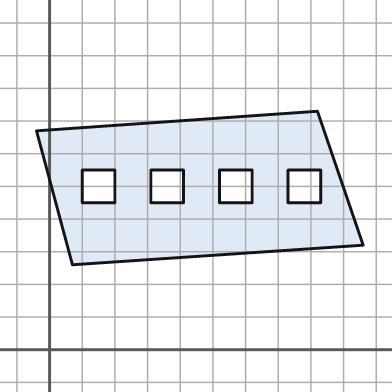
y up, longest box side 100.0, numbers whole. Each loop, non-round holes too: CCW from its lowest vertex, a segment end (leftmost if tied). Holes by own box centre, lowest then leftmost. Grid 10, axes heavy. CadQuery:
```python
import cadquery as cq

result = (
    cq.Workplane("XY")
    .moveTo(7.0, 26.0)
    .lineTo(96.0, 32.0)
    .lineTo(82.0, 73.0)
    .lineTo(-4.0, 67.0)
    .close()
    .moveTo(10.0, 45.0)
    .lineTo(20.0, 45.0)
    .lineTo(20.0, 55.0)
    .lineTo(10.0, 55.0)
    .close()
    .moveTo(31.0, 45.0)
    .lineTo(41.0, 45.0)
    .lineTo(41.0, 55.0)
    .lineTo(31.0, 55.0)
    .close()
    .moveTo(52.0, 45.0)
    .lineTo(62.0, 45.0)
    .lineTo(62.0, 55.0)
    .lineTo(52.0, 55.0)
    .close()
    .moveTo(73.0, 45.0)
    .lineTo(83.0, 45.0)
    .lineTo(83.0, 55.0)
    .lineTo(73.0, 55.0)
    .close()
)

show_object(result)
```